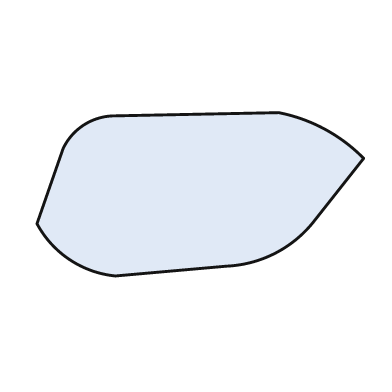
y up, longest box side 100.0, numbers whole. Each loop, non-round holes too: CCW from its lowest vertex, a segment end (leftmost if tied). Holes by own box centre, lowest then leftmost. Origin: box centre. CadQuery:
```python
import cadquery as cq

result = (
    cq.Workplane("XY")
    .moveTo(-26.0, -25.0)
    .lineTo(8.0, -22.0)
    .threePointArc((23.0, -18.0), (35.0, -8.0))
    .lineTo(50.0, 11.0)
    .threePointArc((38.0, 20.0), (24.0, 25.0))
    .lineTo(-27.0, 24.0)
    .threePointArc((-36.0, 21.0), (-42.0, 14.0))
    .lineTo(-50.0, -9.0)
    .threePointArc((-40.0, -20.0), (-26.0, -25.0))
    .close()
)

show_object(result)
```